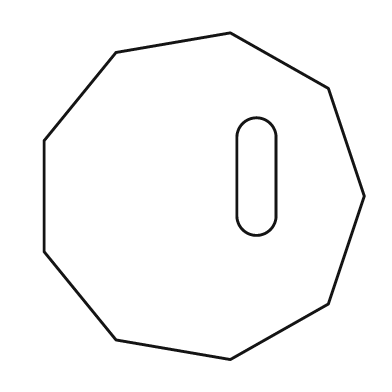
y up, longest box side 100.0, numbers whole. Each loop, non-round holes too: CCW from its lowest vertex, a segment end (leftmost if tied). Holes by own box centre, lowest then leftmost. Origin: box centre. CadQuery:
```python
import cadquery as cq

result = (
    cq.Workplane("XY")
    .moveTo(8.0, -50.0)
    .lineTo(38.0, -33.0)
    .lineTo(49.0, 0.0)
    .lineTo(38.0, 33.0)
    .lineTo(8.0, 50.0)
    .lineTo(-27.0, 44.0)
    .lineTo(-49.0, 17.0)
    .lineTo(-49.0, -17.0)
    .lineTo(-27.0, -44.0)
    .close()
    .moveTo(10.0, -6.0)
    .threePointArc((16.0, -12.0), (22.0, -6.0))
    .lineTo(22.0, 18.0)
    .threePointArc((16.0, 24.0), (10.0, 18.0))
    .close()
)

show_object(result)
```